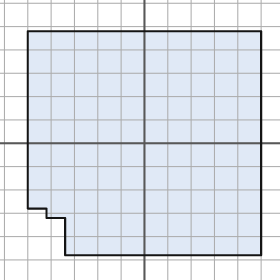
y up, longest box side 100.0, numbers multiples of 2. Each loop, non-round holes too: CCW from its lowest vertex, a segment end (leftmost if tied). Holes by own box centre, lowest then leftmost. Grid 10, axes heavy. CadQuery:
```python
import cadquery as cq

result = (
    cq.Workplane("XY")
    .moveTo(-34.0, -48.0)
    .lineTo(50.0, -48.0)
    .lineTo(50.0, 48.0)
    .lineTo(-50.0, 48.0)
    .lineTo(-50.0, -28.0)
    .lineTo(-42.0, -28.0)
    .lineTo(-42.0, -32.0)
    .lineTo(-34.0, -32.0)
    .close()
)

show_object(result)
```